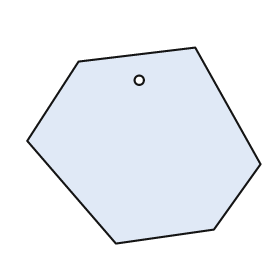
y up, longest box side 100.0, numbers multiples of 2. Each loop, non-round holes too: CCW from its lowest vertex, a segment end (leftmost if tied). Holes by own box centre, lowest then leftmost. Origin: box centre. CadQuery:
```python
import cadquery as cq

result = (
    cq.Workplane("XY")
    .moveTo(-12.0, -42.0)
    .lineTo(30.0, -36.0)
    .lineTo(50.0, -8.0)
    .lineTo(22.0, 42.0)
    .lineTo(-28.0, 36.0)
    .lineTo(-50.0, 2.0)
    .close()
    .moveTo(-2.0, 28.0)
    .circle(2.0)
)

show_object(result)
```